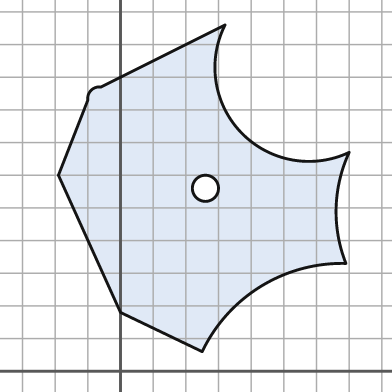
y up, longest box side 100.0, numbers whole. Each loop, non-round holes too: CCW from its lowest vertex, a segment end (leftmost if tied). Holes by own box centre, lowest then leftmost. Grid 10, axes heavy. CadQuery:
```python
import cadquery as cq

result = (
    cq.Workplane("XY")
    .moveTo(25.0, 6.0)
    .threePointArc((43.0, 26.0), (69.0, 33.0))
    .threePointArc((66.0, 50.0), (70.0, 67.0))
    .threePointArc((37.0, 73.0), (32.0, 106.0))
    .lineTo(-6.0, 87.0)
    .threePointArc((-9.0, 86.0), (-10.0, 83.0))
    .lineTo(-19.0, 60.0)
    .lineTo(0.0, 18.0)
    .close()
    .moveTo(26.0, 56.0)
    .circle(4.0)
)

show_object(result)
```